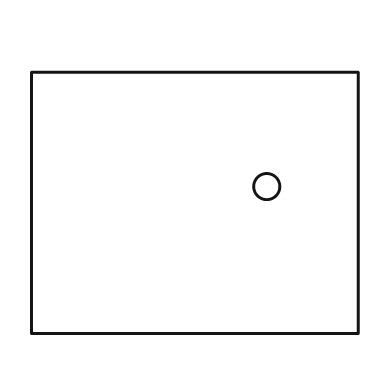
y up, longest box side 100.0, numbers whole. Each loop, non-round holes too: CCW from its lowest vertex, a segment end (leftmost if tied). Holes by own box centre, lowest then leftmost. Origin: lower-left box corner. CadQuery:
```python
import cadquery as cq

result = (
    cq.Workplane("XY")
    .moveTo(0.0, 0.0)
    .lineTo(100.0, 0.0)
    .lineTo(100.0, 80.0)
    .lineTo(0.0, 80.0)
    .close()
    .moveTo(72.0, 45.0)
    .circle(4.0)
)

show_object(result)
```